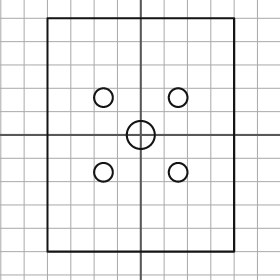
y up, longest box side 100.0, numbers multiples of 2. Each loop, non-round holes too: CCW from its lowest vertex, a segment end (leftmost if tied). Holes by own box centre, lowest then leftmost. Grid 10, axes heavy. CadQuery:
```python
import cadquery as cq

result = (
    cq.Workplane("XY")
    .moveTo(-40.0, -50.0)
    .lineTo(40.0, -50.0)
    .lineTo(40.0, 50.0)
    .lineTo(-40.0, 50.0)
    .close()
    .moveTo(-16.0, -16.0)
    .circle(4.0)
    .moveTo(16.0, -16.0)
    .circle(4.0)
    .moveTo(0.0, 0.0)
    .circle(6.0)
    .moveTo(-16.0, 16.0)
    .circle(4.0)
    .moveTo(16.0, 16.0)
    .circle(4.0)
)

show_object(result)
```